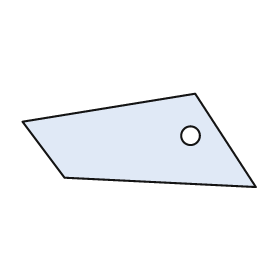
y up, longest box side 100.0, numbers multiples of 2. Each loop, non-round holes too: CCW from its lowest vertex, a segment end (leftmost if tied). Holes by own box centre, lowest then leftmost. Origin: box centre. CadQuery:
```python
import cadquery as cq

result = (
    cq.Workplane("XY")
    .moveTo(50.0, -20.0)
    .lineTo(24.0, 20.0)
    .lineTo(-50.0, 8.0)
    .lineTo(-32.0, -16.0)
    .close()
    .moveTo(22.0, 2.0)
    .circle(4.0)
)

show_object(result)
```